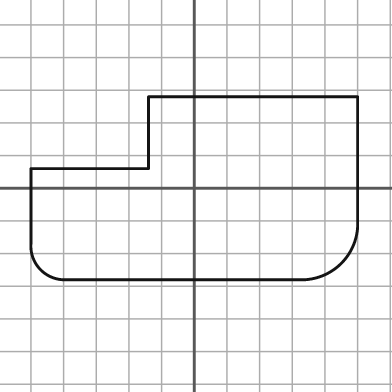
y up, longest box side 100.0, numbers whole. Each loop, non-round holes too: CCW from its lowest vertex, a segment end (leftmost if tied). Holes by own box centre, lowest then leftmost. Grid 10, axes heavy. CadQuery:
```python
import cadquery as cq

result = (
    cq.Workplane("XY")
    .moveTo(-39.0, -28.0)
    .lineTo(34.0, -28.0)
    .threePointArc((45.0, -23.0), (50.0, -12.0))
    .lineTo(50.0, 28.0)
    .lineTo(-14.0, 28.0)
    .lineTo(-14.0, 6.0)
    .lineTo(-50.0, 6.0)
    .lineTo(-50.0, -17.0)
    .threePointArc((-47.0, -25.0), (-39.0, -28.0))
    .close()
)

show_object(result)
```